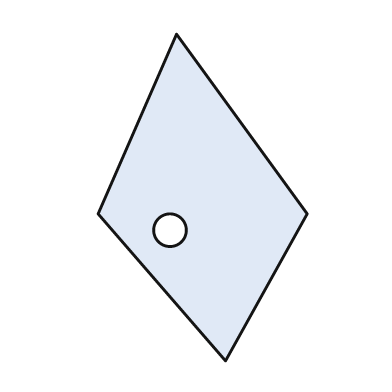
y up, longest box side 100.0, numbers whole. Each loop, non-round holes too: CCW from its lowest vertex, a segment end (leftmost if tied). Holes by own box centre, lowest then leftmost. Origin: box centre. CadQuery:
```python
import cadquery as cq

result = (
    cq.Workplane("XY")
    .moveTo(7.0, -50.0)
    .lineTo(32.0, -5.0)
    .lineTo(-8.0, 50.0)
    .lineTo(-32.0, -5.0)
    .close()
    .moveTo(-10.0, -10.0)
    .circle(5.0)
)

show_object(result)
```